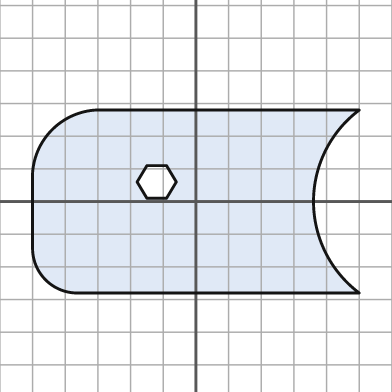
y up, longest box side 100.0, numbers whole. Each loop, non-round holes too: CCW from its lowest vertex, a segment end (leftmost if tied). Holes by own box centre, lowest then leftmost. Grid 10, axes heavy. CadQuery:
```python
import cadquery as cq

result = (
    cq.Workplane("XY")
    .moveTo(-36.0, -28.0)
    .lineTo(50.0, -28.0)
    .threePointArc((36.0, 0.0), (50.0, 28.0))
    .lineTo(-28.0, 28.0)
    .threePointArc((-44.0, 22.0), (-50.0, 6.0))
    .lineTo(-50.0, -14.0)
    .threePointArc((-46.0, -24.0), (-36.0, -28.0))
    .close()
    .moveTo(-15.0, 1.0)
    .lineTo(-9.0, 1.0)
    .lineTo(-6.0, 6.0)
    .lineTo(-9.0, 11.0)
    .lineTo(-15.0, 11.0)
    .lineTo(-18.0, 6.0)
    .close()
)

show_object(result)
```